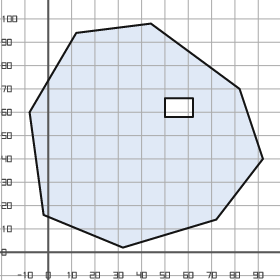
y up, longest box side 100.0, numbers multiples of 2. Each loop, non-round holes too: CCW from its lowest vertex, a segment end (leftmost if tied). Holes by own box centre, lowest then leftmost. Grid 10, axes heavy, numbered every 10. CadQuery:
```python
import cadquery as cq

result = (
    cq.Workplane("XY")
    .moveTo(32.0, 2.0)
    .lineTo(72.0, 14.0)
    .lineTo(92.0, 40.0)
    .lineTo(82.0, 70.0)
    .lineTo(44.0, 98.0)
    .lineTo(12.0, 94.0)
    .lineTo(-8.0, 60.0)
    .lineTo(-2.0, 16.0)
    .close()
    .moveTo(50.0, 58.0)
    .lineTo(62.0, 58.0)
    .lineTo(62.0, 66.0)
    .lineTo(50.0, 66.0)
    .close()
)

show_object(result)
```